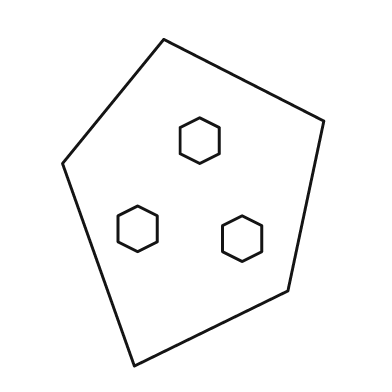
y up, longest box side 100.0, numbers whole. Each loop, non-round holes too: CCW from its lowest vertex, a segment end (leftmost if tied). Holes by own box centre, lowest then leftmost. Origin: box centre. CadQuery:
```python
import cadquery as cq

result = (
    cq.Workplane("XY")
    .moveTo(-18.0, -50.0)
    .lineTo(29.0, -27.0)
    .lineTo(40.0, 25.0)
    .lineTo(-9.0, 50.0)
    .lineTo(-40.0, 12.0)
    .close()
    .moveTo(15.0, -18.0)
    .lineTo(21.0, -15.0)
    .lineTo(21.0, -7.0)
    .lineTo(15.0, -4.0)
    .lineTo(9.0, -7.0)
    .lineTo(9.0, -15.0)
    .close()
    .moveTo(-17.0, -15.0)
    .lineTo(-11.0, -12.0)
    .lineTo(-11.0, -4.0)
    .lineTo(-17.0, -1.0)
    .lineTo(-23.0, -4.0)
    .lineTo(-23.0, -12.0)
    .close()
    .moveTo(2.0, 12.0)
    .lineTo(8.0, 15.0)
    .lineTo(8.0, 23.0)
    .lineTo(2.0, 26.0)
    .lineTo(-4.0, 23.0)
    .lineTo(-4.0, 15.0)
    .close()
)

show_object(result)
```